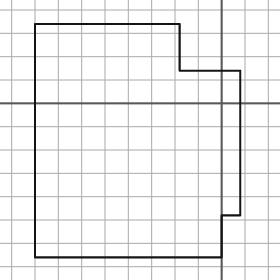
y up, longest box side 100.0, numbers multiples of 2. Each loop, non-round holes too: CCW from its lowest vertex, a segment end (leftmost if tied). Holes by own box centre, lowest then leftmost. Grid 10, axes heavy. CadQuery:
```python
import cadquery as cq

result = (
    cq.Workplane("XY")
    .moveTo(-80.0, -66.0)
    .lineTo(0.0, -66.0)
    .lineTo(0.0, -48.0)
    .lineTo(8.0, -48.0)
    .lineTo(8.0, 14.0)
    .lineTo(-18.0, 14.0)
    .lineTo(-18.0, 34.0)
    .lineTo(-80.0, 34.0)
    .close()
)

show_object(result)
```